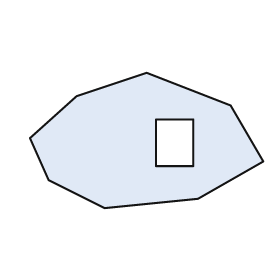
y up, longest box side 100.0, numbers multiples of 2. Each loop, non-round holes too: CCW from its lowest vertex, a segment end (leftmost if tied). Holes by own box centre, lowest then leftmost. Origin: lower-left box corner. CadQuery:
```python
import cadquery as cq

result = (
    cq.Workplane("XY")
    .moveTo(32.0, 0.0)
    .lineTo(72.0, 4.0)
    .lineTo(100.0, 20.0)
    .lineTo(86.0, 44.0)
    .lineTo(50.0, 58.0)
    .lineTo(20.0, 48.0)
    .lineTo(0.0, 30.0)
    .lineTo(8.0, 12.0)
    .close()
    .moveTo(54.0, 18.0)
    .lineTo(70.0, 18.0)
    .lineTo(70.0, 38.0)
    .lineTo(54.0, 38.0)
    .close()
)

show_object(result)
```